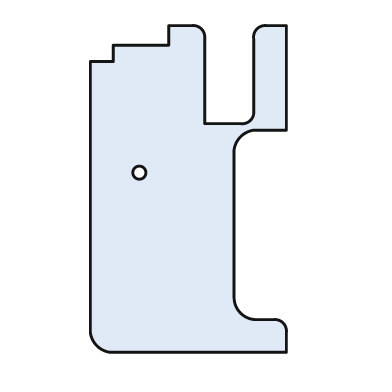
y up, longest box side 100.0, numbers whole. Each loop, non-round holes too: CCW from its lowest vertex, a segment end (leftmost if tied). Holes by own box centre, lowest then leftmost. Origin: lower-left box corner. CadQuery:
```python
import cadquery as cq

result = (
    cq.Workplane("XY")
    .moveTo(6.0, 0.0)
    .lineTo(60.0, 0.0)
    .lineTo(60.0, 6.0)
    .threePointArc((59.0, 9.0), (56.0, 10.0))
    .lineTo(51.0, 10.0)
    .threePointArc((46.0, 12.0), (44.0, 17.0))
    .lineTo(44.0, 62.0)
    .threePointArc((46.0, 66.0), (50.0, 68.0))
    .lineTo(60.0, 68.0)
    .lineTo(60.0, 100.0)
    .lineTo(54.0, 100.0)
    .threePointArc((51.0, 99.0), (50.0, 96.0))
    .lineTo(50.0, 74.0)
    .threePointArc((49.0, 71.0), (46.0, 70.0))
    .lineTo(35.0, 70.0)
    .lineTo(35.0, 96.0)
    .threePointArc((34.0, 99.0), (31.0, 100.0))
    .lineTo(24.0, 100.0)
    .lineTo(24.0, 94.0)
    .lineTo(7.0, 94.0)
    .lineTo(7.0, 89.0)
    .lineTo(0.0, 89.0)
    .lineTo(0.0, 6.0)
    .threePointArc((2.0, 2.0), (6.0, 0.0))
    .close()
    .moveTo(15.0, 55.0)
    .circle(2.0)
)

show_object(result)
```